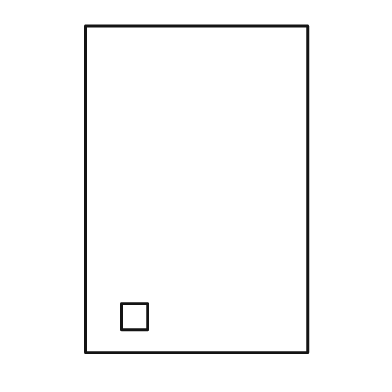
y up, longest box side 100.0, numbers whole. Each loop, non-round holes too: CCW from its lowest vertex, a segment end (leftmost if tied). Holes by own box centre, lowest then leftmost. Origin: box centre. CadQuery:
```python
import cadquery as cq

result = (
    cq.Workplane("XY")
    .moveTo(-34.0, -50.0)
    .lineTo(34.0, -50.0)
    .lineTo(34.0, 50.0)
    .lineTo(-34.0, 50.0)
    .close()
    .moveTo(-23.0, -43.0)
    .lineTo(-15.0, -43.0)
    .lineTo(-15.0, -35.0)
    .lineTo(-23.0, -35.0)
    .close()
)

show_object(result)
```